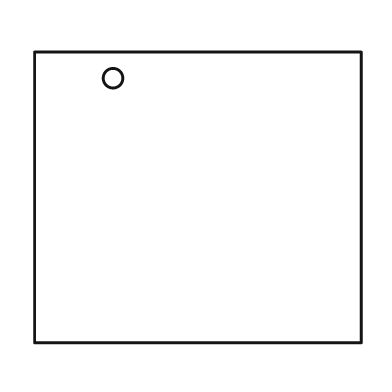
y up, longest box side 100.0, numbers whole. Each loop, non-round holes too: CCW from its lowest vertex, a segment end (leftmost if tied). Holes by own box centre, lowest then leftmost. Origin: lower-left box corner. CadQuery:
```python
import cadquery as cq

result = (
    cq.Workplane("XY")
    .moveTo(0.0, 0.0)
    .lineTo(100.0, 0.0)
    .lineTo(100.0, 89.0)
    .lineTo(0.0, 89.0)
    .close()
    .moveTo(24.0, 81.0)
    .circle(3.0)
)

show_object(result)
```